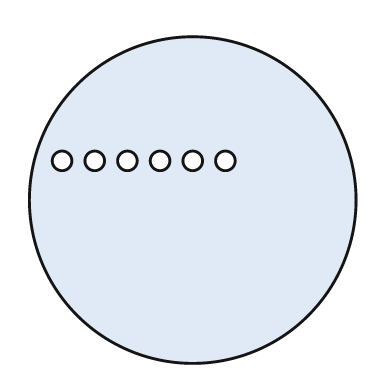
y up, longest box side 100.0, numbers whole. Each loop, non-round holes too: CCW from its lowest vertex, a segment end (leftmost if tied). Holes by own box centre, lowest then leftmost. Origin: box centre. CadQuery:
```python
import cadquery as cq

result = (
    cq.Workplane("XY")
    .moveTo(0.0, 0.0)
    .circle(50.0)
    .moveTo(-40.0, 12.0)
    .circle(3.0)
    .moveTo(-30.0, 12.0)
    .circle(3.0)
    .moveTo(-20.0, 12.0)
    .circle(3.0)
    .moveTo(-10.0, 12.0)
    .circle(3.0)
    .moveTo(0.0, 12.0)
    .circle(3.0)
    .moveTo(10.0, 12.0)
    .circle(3.0)
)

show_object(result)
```